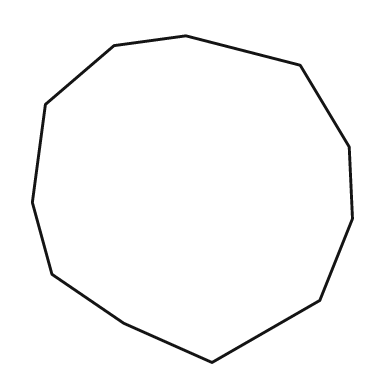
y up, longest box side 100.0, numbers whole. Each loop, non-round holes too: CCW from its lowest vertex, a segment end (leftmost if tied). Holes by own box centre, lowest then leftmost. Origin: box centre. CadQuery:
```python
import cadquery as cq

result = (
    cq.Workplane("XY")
    .moveTo(6.0, -50.0)
    .lineTo(39.0, -31.0)
    .lineTo(49.0, -6.0)
    .lineTo(48.0, 16.0)
    .lineTo(33.0, 41.0)
    .lineTo(-2.0, 50.0)
    .lineTo(-24.0, 47.0)
    .lineTo(-45.0, 29.0)
    .lineTo(-49.0, -1.0)
    .lineTo(-43.0, -23.0)
    .lineTo(-21.0, -38.0)
    .close()
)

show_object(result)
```